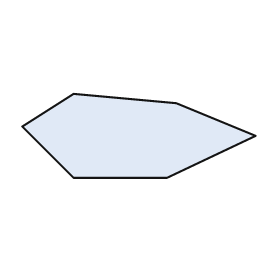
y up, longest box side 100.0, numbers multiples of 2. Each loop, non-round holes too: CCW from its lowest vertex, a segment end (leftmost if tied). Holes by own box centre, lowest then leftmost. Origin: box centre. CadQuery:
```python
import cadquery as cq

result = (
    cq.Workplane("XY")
    .moveTo(-28.0, -18.0)
    .lineTo(12.0, -18.0)
    .lineTo(50.0, 0.0)
    .lineTo(16.0, 14.0)
    .lineTo(-28.0, 18.0)
    .lineTo(-50.0, 4.0)
    .close()
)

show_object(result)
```